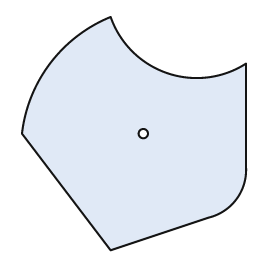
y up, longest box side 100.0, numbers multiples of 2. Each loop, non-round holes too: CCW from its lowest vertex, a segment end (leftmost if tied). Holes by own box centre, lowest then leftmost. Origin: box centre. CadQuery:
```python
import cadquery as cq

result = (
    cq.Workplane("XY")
    .moveTo(-10.0, -50.0)
    .lineTo(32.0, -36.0)
    .threePointArc((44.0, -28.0), (48.0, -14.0))
    .lineTo(48.0, 30.0)
    .threePointArc((14.0, 26.0), (-10.0, 50.0))
    .threePointArc((-36.0, 30.0), (-48.0, 0.0))
    .close()
    .moveTo(4.0, 0.0)
    .circle(2.0)
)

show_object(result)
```